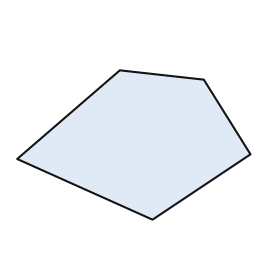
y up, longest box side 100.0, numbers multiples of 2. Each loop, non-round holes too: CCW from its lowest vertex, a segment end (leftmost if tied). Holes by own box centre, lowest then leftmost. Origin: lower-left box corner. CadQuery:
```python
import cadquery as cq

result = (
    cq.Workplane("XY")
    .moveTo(58.0, 0.0)
    .lineTo(100.0, 28.0)
    .lineTo(80.0, 60.0)
    .lineTo(44.0, 64.0)
    .lineTo(0.0, 26.0)
    .close()
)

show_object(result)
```